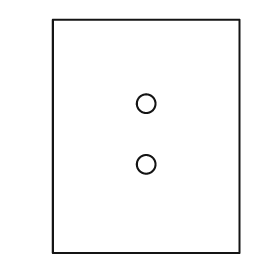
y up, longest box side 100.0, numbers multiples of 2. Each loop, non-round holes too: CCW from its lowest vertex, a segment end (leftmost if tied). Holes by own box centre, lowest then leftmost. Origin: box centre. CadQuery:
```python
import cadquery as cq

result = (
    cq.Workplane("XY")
    .moveTo(-40.0, -50.0)
    .lineTo(40.0, -50.0)
    .lineTo(40.0, 50.0)
    .lineTo(-40.0, 50.0)
    .close()
    .moveTo(0.0, -12.0)
    .circle(4.0)
    .moveTo(0.0, 14.0)
    .circle(4.0)
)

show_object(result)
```